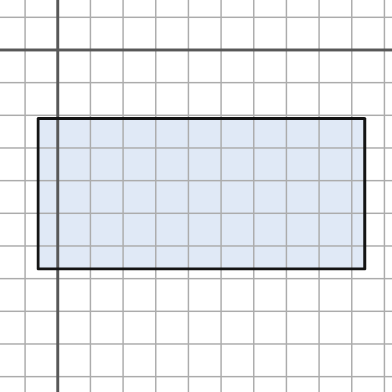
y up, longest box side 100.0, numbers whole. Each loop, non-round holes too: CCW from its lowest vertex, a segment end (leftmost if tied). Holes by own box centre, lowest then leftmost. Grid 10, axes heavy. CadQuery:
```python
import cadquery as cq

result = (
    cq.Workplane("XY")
    .moveTo(-6.0, -67.0)
    .lineTo(94.0, -67.0)
    .lineTo(94.0, -21.0)
    .lineTo(-6.0, -21.0)
    .close()
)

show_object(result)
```